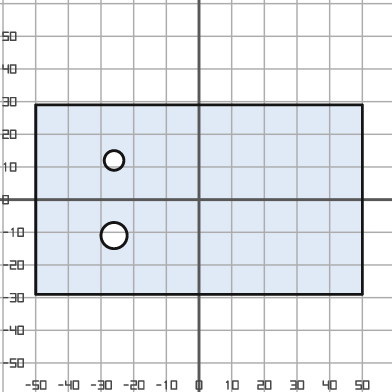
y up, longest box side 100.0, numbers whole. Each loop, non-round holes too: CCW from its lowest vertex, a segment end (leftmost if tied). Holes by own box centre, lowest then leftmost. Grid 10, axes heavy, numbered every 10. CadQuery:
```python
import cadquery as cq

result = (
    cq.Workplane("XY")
    .moveTo(-50.0, -29.0)
    .lineTo(50.0, -29.0)
    .lineTo(50.0, 29.0)
    .lineTo(-50.0, 29.0)
    .close()
    .moveTo(-26.0, -11.0)
    .circle(4.0)
    .moveTo(-26.0, 12.0)
    .circle(3.0)
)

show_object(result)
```